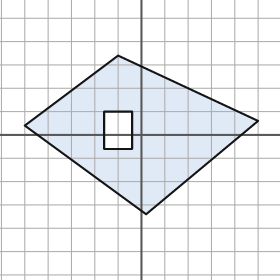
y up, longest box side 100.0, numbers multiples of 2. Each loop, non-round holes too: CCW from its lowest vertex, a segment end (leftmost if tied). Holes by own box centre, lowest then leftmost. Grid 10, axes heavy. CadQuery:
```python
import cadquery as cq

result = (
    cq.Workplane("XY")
    .moveTo(2.0, -34.0)
    .lineTo(50.0, 6.0)
    .lineTo(-10.0, 34.0)
    .lineTo(-50.0, 4.0)
    .close()
    .moveTo(-16.0, -6.0)
    .lineTo(-4.0, -6.0)
    .lineTo(-4.0, 10.0)
    .lineTo(-16.0, 10.0)
    .close()
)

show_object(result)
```